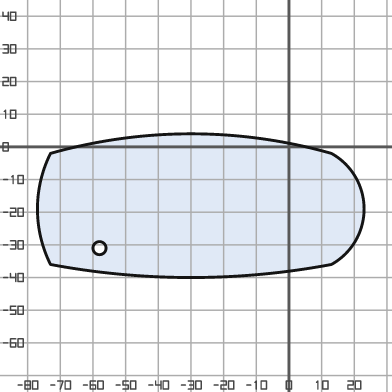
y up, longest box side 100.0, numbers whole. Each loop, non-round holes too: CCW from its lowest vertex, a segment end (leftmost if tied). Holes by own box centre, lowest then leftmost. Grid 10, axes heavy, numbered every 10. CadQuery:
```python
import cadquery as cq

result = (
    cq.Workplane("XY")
    .moveTo(-73.0, -36.0)
    .threePointArc((-30.0, -40.0), (13.0, -36.0))
    .threePointArc((23.0, -19.0), (13.0, -2.0))
    .threePointArc((-30.0, 4.0), (-73.0, -2.0))
    .threePointArc((-77.0, -19.0), (-73.0, -36.0))
    .close()
    .moveTo(-58.0, -31.0)
    .circle(2.0)
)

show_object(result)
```